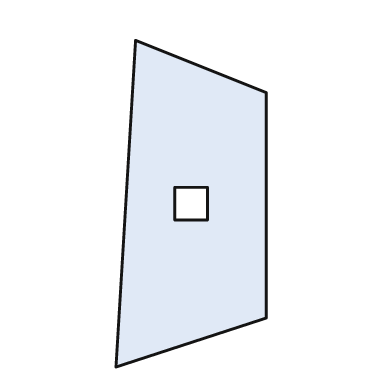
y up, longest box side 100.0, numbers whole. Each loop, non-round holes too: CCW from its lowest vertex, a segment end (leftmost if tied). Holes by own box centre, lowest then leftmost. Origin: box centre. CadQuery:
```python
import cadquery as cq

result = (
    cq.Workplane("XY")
    .moveTo(-23.0, -50.0)
    .lineTo(23.0, -35.0)
    .lineTo(23.0, 34.0)
    .lineTo(-17.0, 50.0)
    .close()
    .moveTo(-5.0, -5.0)
    .lineTo(5.0, -5.0)
    .lineTo(5.0, 5.0)
    .lineTo(-5.0, 5.0)
    .close()
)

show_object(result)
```